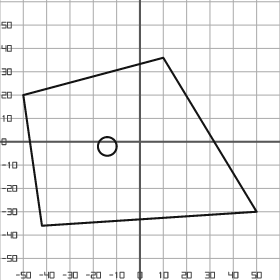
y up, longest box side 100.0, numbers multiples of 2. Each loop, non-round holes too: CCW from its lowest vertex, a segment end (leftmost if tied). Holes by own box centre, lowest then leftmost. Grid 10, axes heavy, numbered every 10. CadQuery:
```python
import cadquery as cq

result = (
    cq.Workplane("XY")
    .moveTo(-42.0, -36.0)
    .lineTo(50.0, -30.0)
    .lineTo(10.0, 36.0)
    .lineTo(-50.0, 20.0)
    .close()
    .moveTo(-14.0, -2.0)
    .circle(4.0)
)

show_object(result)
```